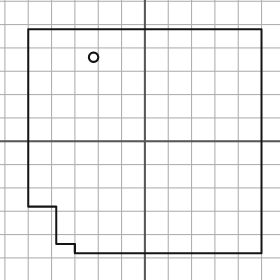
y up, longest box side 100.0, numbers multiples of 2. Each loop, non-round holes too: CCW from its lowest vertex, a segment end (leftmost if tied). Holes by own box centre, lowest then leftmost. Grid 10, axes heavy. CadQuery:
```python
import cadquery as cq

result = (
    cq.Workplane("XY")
    .moveTo(-30.0, -48.0)
    .lineTo(50.0, -48.0)
    .lineTo(50.0, 48.0)
    .lineTo(-50.0, 48.0)
    .lineTo(-50.0, -28.0)
    .lineTo(-38.0, -28.0)
    .lineTo(-38.0, -44.0)
    .lineTo(-30.0, -44.0)
    .close()
    .moveTo(-22.0, 36.0)
    .circle(2.0)
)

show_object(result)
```